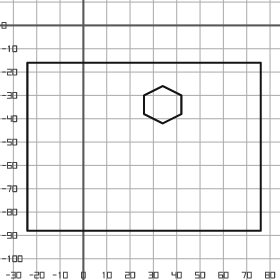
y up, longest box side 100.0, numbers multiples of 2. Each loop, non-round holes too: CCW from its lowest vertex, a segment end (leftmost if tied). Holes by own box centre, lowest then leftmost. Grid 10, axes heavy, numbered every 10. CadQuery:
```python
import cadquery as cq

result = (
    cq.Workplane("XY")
    .moveTo(-24.0, -88.0)
    .lineTo(76.0, -88.0)
    .lineTo(76.0, -16.0)
    .lineTo(-24.0, -16.0)
    .close()
    .moveTo(34.0, -42.0)
    .lineTo(42.0, -38.0)
    .lineTo(42.0, -30.0)
    .lineTo(34.0, -26.0)
    .lineTo(26.0, -30.0)
    .lineTo(26.0, -38.0)
    .close()
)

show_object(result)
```